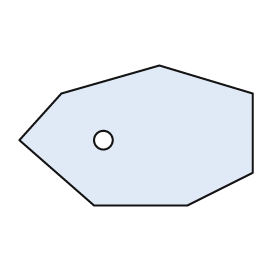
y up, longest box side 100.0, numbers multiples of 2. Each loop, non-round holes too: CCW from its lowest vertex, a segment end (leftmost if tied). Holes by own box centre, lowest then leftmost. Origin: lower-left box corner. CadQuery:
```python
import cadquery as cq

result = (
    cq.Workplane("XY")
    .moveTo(32.0, 0.0)
    .lineTo(72.0, 0.0)
    .lineTo(100.0, 14.0)
    .lineTo(100.0, 48.0)
    .lineTo(60.0, 60.0)
    .lineTo(18.0, 48.0)
    .lineTo(0.0, 28.0)
    .close()
    .moveTo(36.0, 28.0)
    .circle(4.0)
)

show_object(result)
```